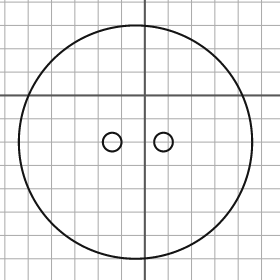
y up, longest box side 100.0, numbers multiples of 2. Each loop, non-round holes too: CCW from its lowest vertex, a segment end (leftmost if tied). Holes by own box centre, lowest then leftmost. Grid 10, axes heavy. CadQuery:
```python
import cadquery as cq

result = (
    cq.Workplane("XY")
    .moveTo(-4.0, -20.0)
    .circle(50.0)
    .moveTo(-14.0, -20.0)
    .circle(4.0)
    .moveTo(8.0, -20.0)
    .circle(4.0)
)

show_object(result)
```